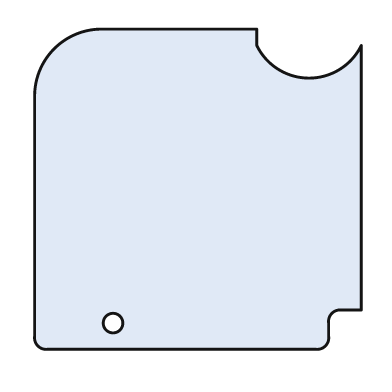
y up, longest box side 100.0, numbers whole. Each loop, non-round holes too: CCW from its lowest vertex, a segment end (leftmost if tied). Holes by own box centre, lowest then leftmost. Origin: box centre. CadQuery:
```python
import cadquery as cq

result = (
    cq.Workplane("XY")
    .moveTo(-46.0, -49.0)
    .lineTo(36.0, -49.0)
    .threePointArc((39.0, -48.0), (40.0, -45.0))
    .lineTo(40.0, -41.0)
    .threePointArc((41.0, -38.0), (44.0, -37.0))
    .lineTo(50.0, -37.0)
    .lineTo(50.0, 44.0)
    .threePointArc((34.0, 34.0), (18.0, 44.0))
    .lineTo(18.0, 49.0)
    .lineTo(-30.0, 49.0)
    .threePointArc((-44.0, 43.0), (-50.0, 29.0))
    .lineTo(-50.0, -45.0)
    .threePointArc((-49.0, -48.0), (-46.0, -49.0))
    .close()
    .moveTo(-26.0, -41.0)
    .circle(3.0)
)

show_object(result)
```